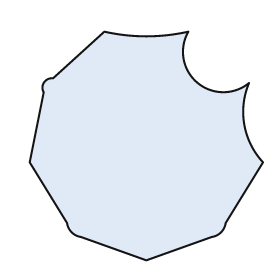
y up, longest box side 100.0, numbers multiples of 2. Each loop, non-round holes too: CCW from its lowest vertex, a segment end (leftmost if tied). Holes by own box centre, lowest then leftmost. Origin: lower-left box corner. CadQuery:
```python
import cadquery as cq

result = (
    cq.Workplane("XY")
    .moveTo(50.0, 0.0)
    .lineTo(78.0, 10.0)
    .threePointArc((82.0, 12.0), (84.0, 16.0))
    .lineTo(100.0, 42.0)
    .threePointArc((92.0, 58.0), (94.0, 76.0))
    .threePointArc((72.0, 76.0), (68.0, 98.0))
    .threePointArc((50.0, 96.0), (32.0, 98.0))
    .lineTo(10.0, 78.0)
    .threePointArc((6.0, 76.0), (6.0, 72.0))
    .lineTo(0.0, 42.0)
    .lineTo(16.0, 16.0)
    .threePointArc((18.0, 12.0), (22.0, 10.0))
    .close()
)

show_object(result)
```